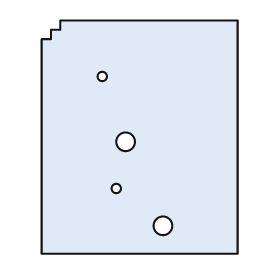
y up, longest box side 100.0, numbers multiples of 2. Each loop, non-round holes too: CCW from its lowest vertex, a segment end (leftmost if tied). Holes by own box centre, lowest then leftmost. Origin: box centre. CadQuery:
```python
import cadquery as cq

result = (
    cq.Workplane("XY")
    .moveTo(-42.0, -50.0)
    .lineTo(42.0, -50.0)
    .lineTo(42.0, 50.0)
    .lineTo(-34.0, 50.0)
    .lineTo(-34.0, 46.0)
    .lineTo(-38.0, 46.0)
    .lineTo(-38.0, 42.0)
    .lineTo(-42.0, 42.0)
    .close()
    .moveTo(10.0, -38.0)
    .circle(4.0)
    .moveTo(-10.0, -22.0)
    .circle(2.0)
    .moveTo(-6.0, -2.0)
    .circle(4.0)
    .moveTo(-16.0, 26.0)
    .circle(2.0)
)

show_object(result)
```